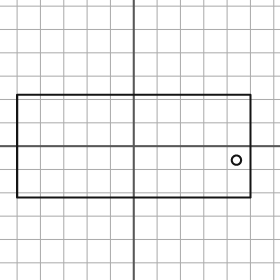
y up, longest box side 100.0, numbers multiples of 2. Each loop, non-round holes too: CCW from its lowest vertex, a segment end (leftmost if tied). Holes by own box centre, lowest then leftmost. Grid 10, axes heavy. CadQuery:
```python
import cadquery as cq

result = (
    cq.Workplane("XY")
    .moveTo(-50.0, -22.0)
    .lineTo(50.0, -22.0)
    .lineTo(50.0, 22.0)
    .lineTo(-50.0, 22.0)
    .close()
    .moveTo(44.0, -6.0)
    .circle(2.0)
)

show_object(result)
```